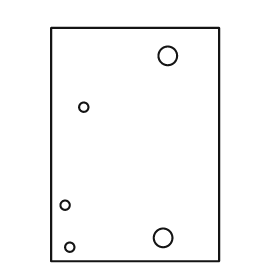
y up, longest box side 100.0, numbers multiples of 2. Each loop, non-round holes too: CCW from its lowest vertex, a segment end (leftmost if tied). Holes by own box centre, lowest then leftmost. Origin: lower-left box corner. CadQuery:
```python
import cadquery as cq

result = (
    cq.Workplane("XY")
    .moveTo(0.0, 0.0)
    .lineTo(72.0, 0.0)
    .lineTo(72.0, 100.0)
    .lineTo(0.0, 100.0)
    .close()
    .moveTo(8.0, 6.0)
    .circle(2.0)
    .moveTo(48.0, 10.0)
    .circle(4.0)
    .moveTo(6.0, 24.0)
    .circle(2.0)
    .moveTo(14.0, 66.0)
    .circle(2.0)
    .moveTo(50.0, 88.0)
    .circle(4.0)
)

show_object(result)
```